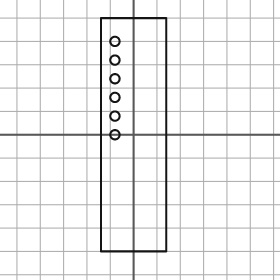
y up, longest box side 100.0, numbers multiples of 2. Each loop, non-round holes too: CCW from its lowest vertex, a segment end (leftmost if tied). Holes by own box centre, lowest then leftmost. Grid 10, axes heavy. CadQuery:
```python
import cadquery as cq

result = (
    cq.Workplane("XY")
    .moveTo(-14.0, -50.0)
    .lineTo(14.0, -50.0)
    .lineTo(14.0, 50.0)
    .lineTo(-14.0, 50.0)
    .close()
    .moveTo(-8.0, 0.0)
    .circle(2.0)
    .moveTo(-8.0, 8.0)
    .circle(2.0)
    .moveTo(-8.0, 16.0)
    .circle(2.0)
    .moveTo(-8.0, 24.0)
    .circle(2.0)
    .moveTo(-8.0, 32.0)
    .circle(2.0)
    .moveTo(-8.0, 40.0)
    .circle(2.0)
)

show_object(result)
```